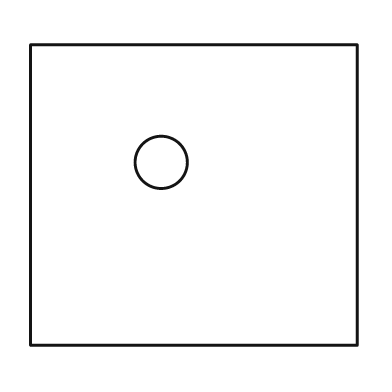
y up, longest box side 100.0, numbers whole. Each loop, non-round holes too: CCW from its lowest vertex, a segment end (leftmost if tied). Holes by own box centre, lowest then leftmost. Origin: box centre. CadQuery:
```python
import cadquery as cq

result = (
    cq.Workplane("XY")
    .moveTo(-50.0, -46.0)
    .lineTo(50.0, -46.0)
    .lineTo(50.0, 46.0)
    .lineTo(-50.0, 46.0)
    .close()
    .moveTo(-10.0, 10.0)
    .circle(8.0)
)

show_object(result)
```